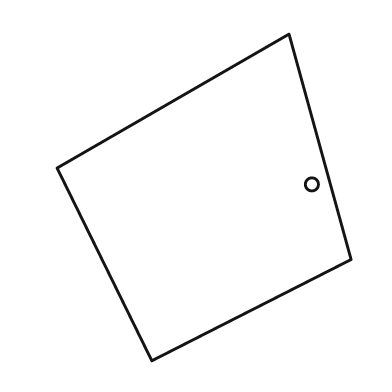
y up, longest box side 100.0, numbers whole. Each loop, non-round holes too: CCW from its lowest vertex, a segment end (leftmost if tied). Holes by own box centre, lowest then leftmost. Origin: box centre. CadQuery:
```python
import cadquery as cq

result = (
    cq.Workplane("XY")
    .moveTo(-16.0, -50.0)
    .lineTo(45.0, -19.0)
    .lineTo(26.0, 50.0)
    .lineTo(-45.0, 9.0)
    .close()
    .moveTo(33.0, 4.0)
    .circle(2.0)
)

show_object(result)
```